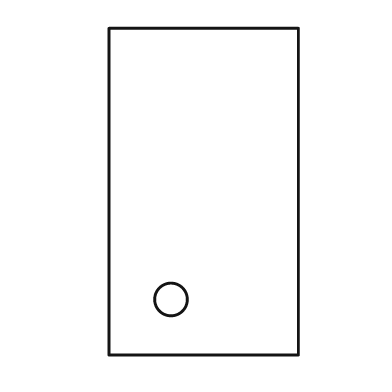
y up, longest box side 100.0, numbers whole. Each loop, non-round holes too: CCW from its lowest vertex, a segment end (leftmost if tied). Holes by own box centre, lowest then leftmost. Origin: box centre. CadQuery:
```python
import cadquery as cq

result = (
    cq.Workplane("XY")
    .moveTo(-29.0, -50.0)
    .lineTo(29.0, -50.0)
    .lineTo(29.0, 50.0)
    .lineTo(-29.0, 50.0)
    .close()
    .moveTo(-10.0, -33.0)
    .circle(5.0)
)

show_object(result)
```